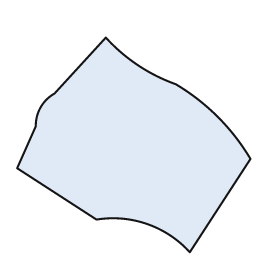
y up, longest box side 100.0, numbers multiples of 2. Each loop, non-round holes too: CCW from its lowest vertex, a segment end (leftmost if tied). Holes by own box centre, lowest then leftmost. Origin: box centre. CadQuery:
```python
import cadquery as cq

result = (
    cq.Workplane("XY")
    .moveTo(24.0, -46.0)
    .lineTo(50.0, -6.0)
    .threePointArc((36.0, 12.0), (18.0, 26.0))
    .threePointArc((2.0, 34.0), (-12.0, 46.0))
    .lineTo(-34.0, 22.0)
    .threePointArc((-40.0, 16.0), (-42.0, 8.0))
    .lineTo(-50.0, -10.0)
    .lineTo(-16.0, -32.0)
    .threePointArc((6.0, -34.0), (24.0, -46.0))
    .close()
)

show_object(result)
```